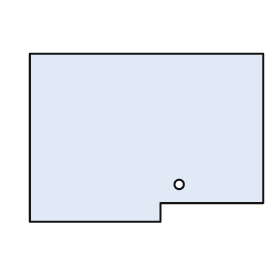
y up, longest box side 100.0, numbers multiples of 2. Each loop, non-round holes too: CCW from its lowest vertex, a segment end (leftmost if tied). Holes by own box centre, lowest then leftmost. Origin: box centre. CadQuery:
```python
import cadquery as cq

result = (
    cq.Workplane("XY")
    .moveTo(-50.0, -36.0)
    .lineTo(6.0, -36.0)
    .lineTo(6.0, -28.0)
    .lineTo(50.0, -28.0)
    .lineTo(50.0, 36.0)
    .lineTo(-50.0, 36.0)
    .close()
    .moveTo(14.0, -20.0)
    .circle(2.0)
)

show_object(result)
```